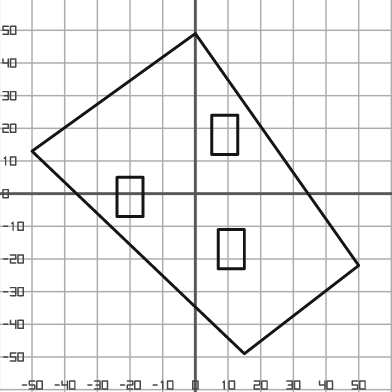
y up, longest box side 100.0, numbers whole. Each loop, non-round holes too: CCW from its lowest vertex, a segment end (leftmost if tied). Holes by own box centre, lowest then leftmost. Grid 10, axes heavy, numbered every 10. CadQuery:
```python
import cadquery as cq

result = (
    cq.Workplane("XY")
    .moveTo(15.0, -49.0)
    .lineTo(50.0, -22.0)
    .lineTo(0.0, 49.0)
    .lineTo(-50.0, 13.0)
    .close()
    .moveTo(7.0, -23.0)
    .lineTo(15.0, -23.0)
    .lineTo(15.0, -11.0)
    .lineTo(7.0, -11.0)
    .close()
    .moveTo(-24.0, -7.0)
    .lineTo(-16.0, -7.0)
    .lineTo(-16.0, 5.0)
    .lineTo(-24.0, 5.0)
    .close()
    .moveTo(5.0, 12.0)
    .lineTo(13.0, 12.0)
    .lineTo(13.0, 24.0)
    .lineTo(5.0, 24.0)
    .close()
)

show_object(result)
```